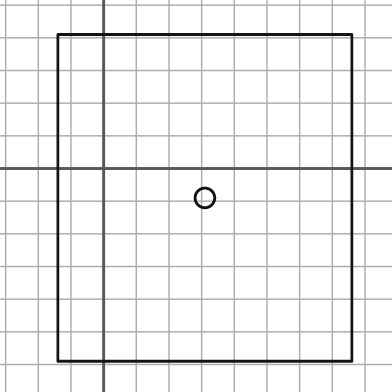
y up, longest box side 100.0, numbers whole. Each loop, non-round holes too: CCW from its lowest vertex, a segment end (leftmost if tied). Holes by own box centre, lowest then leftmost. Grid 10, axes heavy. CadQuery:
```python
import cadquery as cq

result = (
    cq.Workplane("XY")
    .moveTo(-14.0, -59.0)
    .lineTo(76.0, -59.0)
    .lineTo(76.0, 41.0)
    .lineTo(-14.0, 41.0)
    .close()
    .moveTo(31.0, -9.0)
    .circle(3.0)
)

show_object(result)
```